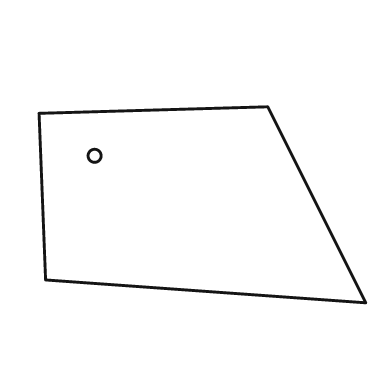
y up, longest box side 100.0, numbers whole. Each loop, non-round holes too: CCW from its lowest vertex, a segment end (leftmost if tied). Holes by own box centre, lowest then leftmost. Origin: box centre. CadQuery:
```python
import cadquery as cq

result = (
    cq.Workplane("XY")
    .moveTo(50.0, -30.0)
    .lineTo(20.0, 30.0)
    .lineTo(-50.0, 28.0)
    .lineTo(-48.0, -23.0)
    .close()
    .moveTo(-33.0, 15.0)
    .circle(2.0)
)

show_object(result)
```